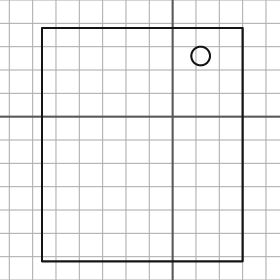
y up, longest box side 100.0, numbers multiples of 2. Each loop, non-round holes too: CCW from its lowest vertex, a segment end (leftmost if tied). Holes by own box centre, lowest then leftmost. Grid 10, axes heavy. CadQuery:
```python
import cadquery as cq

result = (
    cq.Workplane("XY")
    .moveTo(-56.0, -62.0)
    .lineTo(30.0, -62.0)
    .lineTo(30.0, 38.0)
    .lineTo(-56.0, 38.0)
    .close()
    .moveTo(12.0, 26.0)
    .circle(4.0)
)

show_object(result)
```